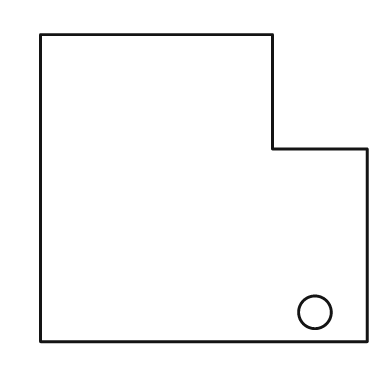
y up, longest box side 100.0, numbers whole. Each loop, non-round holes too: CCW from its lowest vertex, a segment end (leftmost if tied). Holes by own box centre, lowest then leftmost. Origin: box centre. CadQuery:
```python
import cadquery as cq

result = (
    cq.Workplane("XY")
    .moveTo(-50.0, -47.0)
    .lineTo(50.0, -47.0)
    .lineTo(50.0, 12.0)
    .lineTo(21.0, 12.0)
    .lineTo(21.0, 47.0)
    .lineTo(-50.0, 47.0)
    .close()
    .moveTo(34.0, -38.0)
    .circle(5.0)
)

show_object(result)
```